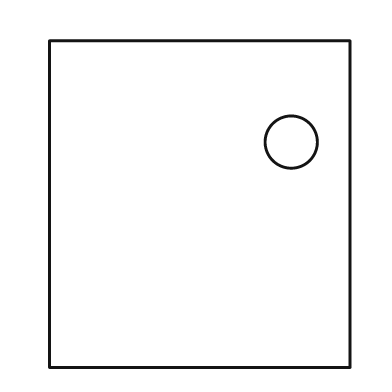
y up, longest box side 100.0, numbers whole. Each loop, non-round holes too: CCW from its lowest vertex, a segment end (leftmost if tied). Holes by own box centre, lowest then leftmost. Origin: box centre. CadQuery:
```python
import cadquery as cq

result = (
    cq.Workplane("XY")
    .moveTo(-46.0, -50.0)
    .lineTo(46.0, -50.0)
    .lineTo(46.0, 50.0)
    .lineTo(-46.0, 50.0)
    .close()
    .moveTo(28.0, 19.0)
    .circle(8.0)
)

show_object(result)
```